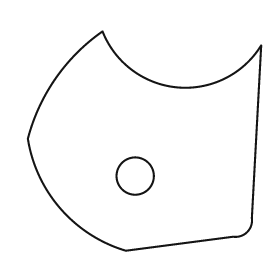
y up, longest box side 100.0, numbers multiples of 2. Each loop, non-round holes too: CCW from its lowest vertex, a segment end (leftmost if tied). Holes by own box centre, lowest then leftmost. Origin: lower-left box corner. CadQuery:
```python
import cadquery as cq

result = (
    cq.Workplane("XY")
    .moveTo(42.0, 0.0)
    .lineTo(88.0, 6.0)
    .threePointArc((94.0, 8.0), (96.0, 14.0))
    .lineTo(100.0, 88.0)
    .threePointArc((64.0, 70.0), (32.0, 94.0))
    .threePointArc((12.0, 74.0), (0.0, 48.0))
    .threePointArc((14.0, 18.0), (42.0, 0.0))
    .close()
    .moveTo(46.0, 32.0)
    .circle(8.0)
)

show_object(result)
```